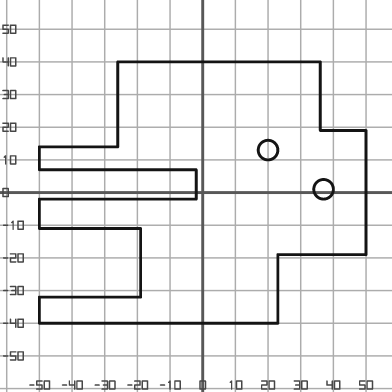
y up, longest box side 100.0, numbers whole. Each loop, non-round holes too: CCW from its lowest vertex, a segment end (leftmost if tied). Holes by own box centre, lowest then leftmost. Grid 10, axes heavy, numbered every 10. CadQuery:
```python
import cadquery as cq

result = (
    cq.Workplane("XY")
    .moveTo(-50.0, -40.0)
    .lineTo(23.0, -40.0)
    .lineTo(23.0, -19.0)
    .lineTo(50.0, -19.0)
    .lineTo(50.0, 19.0)
    .lineTo(36.0, 19.0)
    .lineTo(36.0, 40.0)
    .lineTo(-26.0, 40.0)
    .lineTo(-26.0, 14.0)
    .lineTo(-50.0, 14.0)
    .lineTo(-50.0, 7.0)
    .lineTo(-2.0, 7.0)
    .lineTo(-2.0, -2.0)
    .lineTo(-50.0, -2.0)
    .lineTo(-50.0, -11.0)
    .lineTo(-19.0, -11.0)
    .lineTo(-19.0, -32.0)
    .lineTo(-50.0, -32.0)
    .close()
    .moveTo(37.0, 1.0)
    .circle(3.0)
    .moveTo(20.0, 13.0)
    .circle(3.0)
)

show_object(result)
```